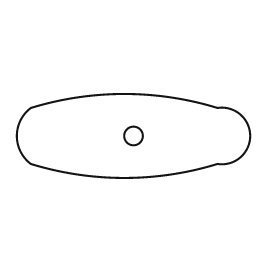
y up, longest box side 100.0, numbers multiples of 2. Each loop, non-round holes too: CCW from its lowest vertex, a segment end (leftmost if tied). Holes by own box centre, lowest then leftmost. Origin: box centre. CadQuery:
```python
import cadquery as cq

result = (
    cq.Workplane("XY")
    .moveTo(-44.0, -12.0)
    .threePointArc((-4.0, -18.0), (36.0, -12.0))
    .threePointArc((50.0, 0.0), (36.0, 12.0))
    .threePointArc((-4.0, 18.0), (-44.0, 12.0))
    .threePointArc((-50.0, 0.0), (-44.0, -12.0))
    .close()
    .moveTo(0.0, 0.0)
    .circle(4.0)
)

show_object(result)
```